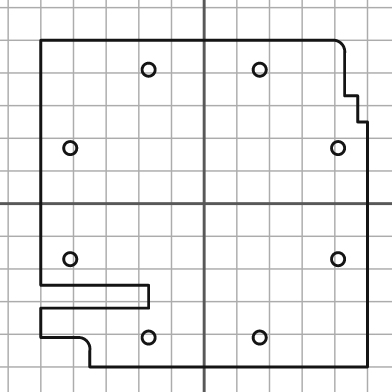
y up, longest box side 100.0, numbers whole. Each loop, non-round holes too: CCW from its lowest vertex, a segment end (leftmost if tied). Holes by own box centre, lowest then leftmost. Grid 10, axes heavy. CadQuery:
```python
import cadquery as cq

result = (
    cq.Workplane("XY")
    .moveTo(-35.0, -50.0)
    .lineTo(50.0, -50.0)
    .lineTo(50.0, 25.0)
    .lineTo(47.0, 25.0)
    .lineTo(47.0, 33.0)
    .lineTo(43.0, 33.0)
    .lineTo(43.0, 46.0)
    .threePointArc((42.0, 49.0), (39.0, 50.0))
    .lineTo(-50.0, 50.0)
    .lineTo(-50.0, -25.0)
    .lineTo(-17.0, -25.0)
    .lineTo(-17.0, -32.0)
    .lineTo(-50.0, -32.0)
    .lineTo(-50.0, -41.0)
    .lineTo(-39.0, -41.0)
    .threePointArc((-36.0, -42.0), (-35.0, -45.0))
    .close()
    .moveTo(-17.0, -41.0)
    .circle(2.0)
    .moveTo(17.0, -41.0)
    .circle(2.0)
    .moveTo(-41.0, -17.0)
    .circle(2.0)
    .moveTo(41.0, -17.0)
    .circle(2.0)
    .moveTo(-41.0, 17.0)
    .circle(2.0)
    .moveTo(41.0, 17.0)
    .circle(2.0)
    .moveTo(-17.0, 41.0)
    .circle(2.0)
    .moveTo(17.0, 41.0)
    .circle(2.0)
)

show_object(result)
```